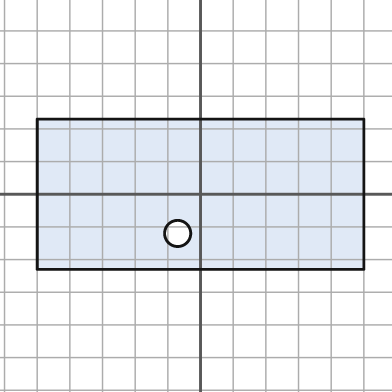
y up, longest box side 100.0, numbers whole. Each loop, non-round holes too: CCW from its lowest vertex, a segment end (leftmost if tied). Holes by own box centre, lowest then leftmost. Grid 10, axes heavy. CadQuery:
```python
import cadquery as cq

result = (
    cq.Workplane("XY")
    .moveTo(-50.0, -23.0)
    .lineTo(50.0, -23.0)
    .lineTo(50.0, 23.0)
    .lineTo(-50.0, 23.0)
    .close()
    .moveTo(-7.0, -12.0)
    .circle(4.0)
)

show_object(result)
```